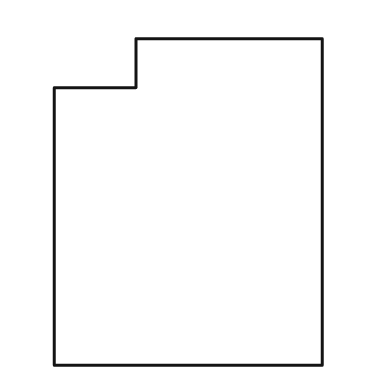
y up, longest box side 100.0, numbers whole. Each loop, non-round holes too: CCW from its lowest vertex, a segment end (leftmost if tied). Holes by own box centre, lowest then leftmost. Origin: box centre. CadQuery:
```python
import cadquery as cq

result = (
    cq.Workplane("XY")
    .moveTo(-41.0, -50.0)
    .lineTo(41.0, -50.0)
    .lineTo(41.0, 50.0)
    .lineTo(-16.0, 50.0)
    .lineTo(-16.0, 35.0)
    .lineTo(-41.0, 35.0)
    .close()
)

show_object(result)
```